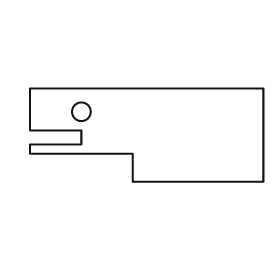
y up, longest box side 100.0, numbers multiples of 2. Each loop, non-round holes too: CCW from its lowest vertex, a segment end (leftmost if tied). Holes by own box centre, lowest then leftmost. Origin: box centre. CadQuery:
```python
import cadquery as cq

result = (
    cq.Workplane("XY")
    .moveTo(-6.0, -20.0)
    .lineTo(50.0, -20.0)
    .lineTo(50.0, 20.0)
    .lineTo(-50.0, 20.0)
    .lineTo(-50.0, 2.0)
    .lineTo(-28.0, 2.0)
    .lineTo(-28.0, -4.0)
    .lineTo(-50.0, -4.0)
    .lineTo(-50.0, -8.0)
    .lineTo(-6.0, -8.0)
    .close()
    .moveTo(-28.0, 10.0)
    .circle(4.0)
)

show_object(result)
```